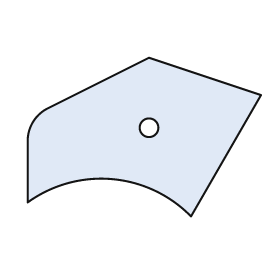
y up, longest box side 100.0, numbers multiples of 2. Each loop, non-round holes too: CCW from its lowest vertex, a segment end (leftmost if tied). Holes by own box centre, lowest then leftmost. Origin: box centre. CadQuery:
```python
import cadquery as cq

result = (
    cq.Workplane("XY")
    .moveTo(20.0, -34.0)
    .lineTo(50.0, 18.0)
    .lineTo(2.0, 34.0)
    .lineTo(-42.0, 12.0)
    .threePointArc((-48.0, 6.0), (-50.0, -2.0))
    .lineTo(-50.0, -28.0)
    .threePointArc((-14.0, -18.0), (20.0, -34.0))
    .close()
    .moveTo(2.0, 4.0)
    .circle(4.0)
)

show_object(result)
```